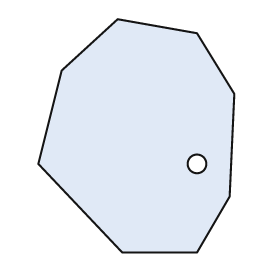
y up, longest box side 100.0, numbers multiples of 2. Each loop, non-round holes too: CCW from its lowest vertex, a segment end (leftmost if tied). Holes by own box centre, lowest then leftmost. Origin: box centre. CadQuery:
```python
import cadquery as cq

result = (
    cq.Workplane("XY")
    .moveTo(-6.0, -50.0)
    .lineTo(26.0, -50.0)
    .lineTo(40.0, -26.0)
    .lineTo(42.0, 18.0)
    .lineTo(26.0, 44.0)
    .lineTo(-8.0, 50.0)
    .lineTo(-32.0, 28.0)
    .lineTo(-42.0, -12.0)
    .close()
    .moveTo(26.0, -12.0)
    .circle(4.0)
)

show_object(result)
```